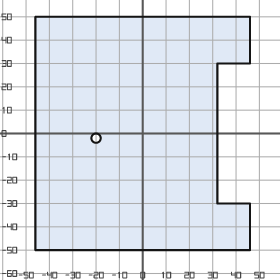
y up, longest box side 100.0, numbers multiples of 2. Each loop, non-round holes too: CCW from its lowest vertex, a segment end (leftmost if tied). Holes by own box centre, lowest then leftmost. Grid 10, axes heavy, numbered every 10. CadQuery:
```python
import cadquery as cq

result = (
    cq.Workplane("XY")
    .moveTo(-46.0, -50.0)
    .lineTo(46.0, -50.0)
    .lineTo(46.0, -30.0)
    .lineTo(32.0, -30.0)
    .lineTo(32.0, 30.0)
    .lineTo(46.0, 30.0)
    .lineTo(46.0, 50.0)
    .lineTo(-46.0, 50.0)
    .close()
    .moveTo(-20.0, -2.0)
    .circle(2.0)
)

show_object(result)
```